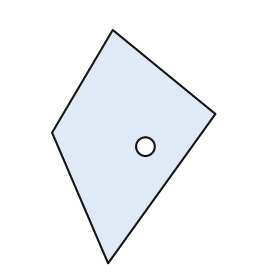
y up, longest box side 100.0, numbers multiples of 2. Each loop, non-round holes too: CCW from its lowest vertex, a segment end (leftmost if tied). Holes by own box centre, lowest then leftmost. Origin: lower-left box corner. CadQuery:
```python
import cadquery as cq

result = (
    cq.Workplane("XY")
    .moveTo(24.0, 0.0)
    .lineTo(70.0, 64.0)
    .lineTo(26.0, 100.0)
    .lineTo(0.0, 56.0)
    .close()
    .moveTo(40.0, 50.0)
    .circle(4.0)
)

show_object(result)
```